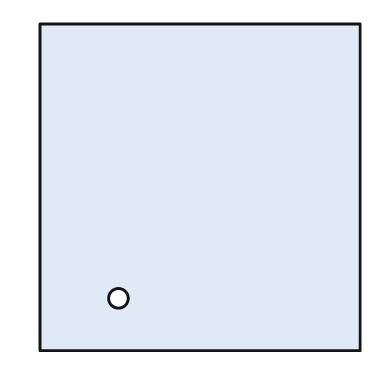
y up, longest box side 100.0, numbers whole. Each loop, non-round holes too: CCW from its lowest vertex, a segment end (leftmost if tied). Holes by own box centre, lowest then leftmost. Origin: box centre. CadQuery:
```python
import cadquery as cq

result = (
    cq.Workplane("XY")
    .moveTo(-49.0, -50.0)
    .lineTo(49.0, -50.0)
    .lineTo(49.0, 50.0)
    .lineTo(-49.0, 50.0)
    .close()
    .moveTo(-25.0, -34.0)
    .circle(3.0)
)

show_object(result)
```